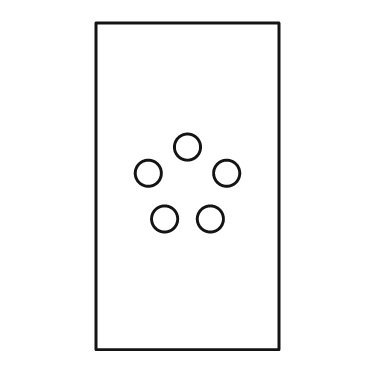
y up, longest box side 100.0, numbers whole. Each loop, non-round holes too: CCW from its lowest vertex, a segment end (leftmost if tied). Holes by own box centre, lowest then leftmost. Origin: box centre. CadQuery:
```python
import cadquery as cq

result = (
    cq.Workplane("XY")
    .moveTo(-28.0, -50.0)
    .lineTo(28.0, -50.0)
    .lineTo(28.0, 50.0)
    .lineTo(-28.0, 50.0)
    .close()
    .moveTo(-7.0, -10.0)
    .circle(4.0)
    .moveTo(7.0, -10.0)
    .circle(4.0)
    .moveTo(-12.0, 4.0)
    .circle(4.0)
    .moveTo(12.0, 4.0)
    .circle(4.0)
    .moveTo(0.0, 12.0)
    .circle(4.0)
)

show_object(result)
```